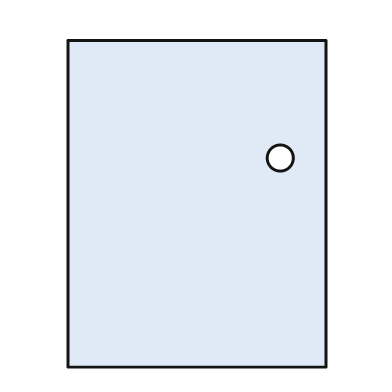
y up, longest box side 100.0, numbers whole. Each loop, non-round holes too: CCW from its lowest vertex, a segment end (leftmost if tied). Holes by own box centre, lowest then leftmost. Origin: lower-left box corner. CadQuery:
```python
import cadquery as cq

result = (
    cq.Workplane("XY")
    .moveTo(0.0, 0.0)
    .lineTo(79.0, 0.0)
    .lineTo(79.0, 100.0)
    .lineTo(0.0, 100.0)
    .close()
    .moveTo(65.0, 64.0)
    .circle(4.0)
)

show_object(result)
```